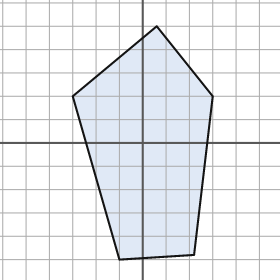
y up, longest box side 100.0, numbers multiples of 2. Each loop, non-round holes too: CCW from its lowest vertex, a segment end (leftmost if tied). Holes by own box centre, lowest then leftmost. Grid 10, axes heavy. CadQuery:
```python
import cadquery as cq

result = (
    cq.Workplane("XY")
    .moveTo(-10.0, -50.0)
    .lineTo(22.0, -48.0)
    .lineTo(30.0, 20.0)
    .lineTo(6.0, 50.0)
    .lineTo(-30.0, 20.0)
    .close()
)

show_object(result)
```